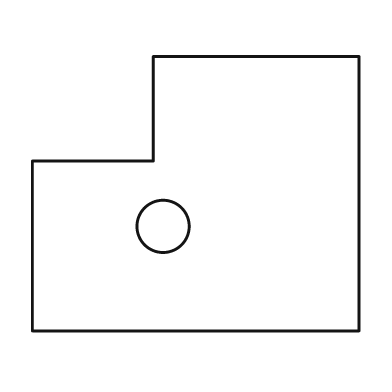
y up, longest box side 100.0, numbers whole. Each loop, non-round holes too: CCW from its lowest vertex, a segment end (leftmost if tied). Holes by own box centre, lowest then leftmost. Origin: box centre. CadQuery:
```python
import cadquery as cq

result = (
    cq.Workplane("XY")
    .moveTo(-50.0, -42.0)
    .lineTo(50.0, -42.0)
    .lineTo(50.0, 42.0)
    .lineTo(-13.0, 42.0)
    .lineTo(-13.0, 10.0)
    .lineTo(-50.0, 10.0)
    .close()
    .moveTo(-10.0, -10.0)
    .circle(8.0)
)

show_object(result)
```